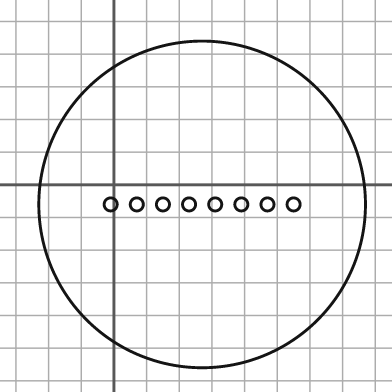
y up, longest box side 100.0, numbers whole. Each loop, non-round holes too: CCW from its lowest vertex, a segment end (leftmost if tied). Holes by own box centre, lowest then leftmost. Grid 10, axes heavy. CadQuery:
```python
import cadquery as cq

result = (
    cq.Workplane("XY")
    .moveTo(27.0, -6.0)
    .circle(50.0)
    .moveTo(-1.0, -6.0)
    .circle(2.0)
    .moveTo(7.0, -6.0)
    .circle(2.0)
    .moveTo(15.0, -6.0)
    .circle(2.0)
    .moveTo(23.0, -6.0)
    .circle(2.0)
    .moveTo(31.0, -6.0)
    .circle(2.0)
    .moveTo(39.0, -6.0)
    .circle(2.0)
    .moveTo(47.0, -6.0)
    .circle(2.0)
    .moveTo(55.0, -6.0)
    .circle(2.0)
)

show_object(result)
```